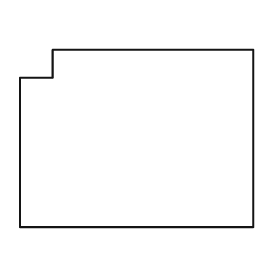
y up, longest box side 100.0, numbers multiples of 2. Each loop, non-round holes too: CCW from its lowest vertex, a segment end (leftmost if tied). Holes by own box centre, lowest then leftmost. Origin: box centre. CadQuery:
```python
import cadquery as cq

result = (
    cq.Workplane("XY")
    .moveTo(-50.0, -38.0)
    .lineTo(50.0, -38.0)
    .lineTo(50.0, 38.0)
    .lineTo(-36.0, 38.0)
    .lineTo(-36.0, 26.0)
    .lineTo(-50.0, 26.0)
    .close()
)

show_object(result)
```